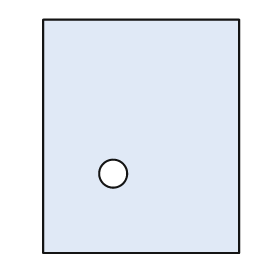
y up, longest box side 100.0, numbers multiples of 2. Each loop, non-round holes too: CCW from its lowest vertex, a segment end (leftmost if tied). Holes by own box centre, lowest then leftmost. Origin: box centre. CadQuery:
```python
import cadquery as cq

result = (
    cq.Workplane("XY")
    .moveTo(-42.0, -50.0)
    .lineTo(42.0, -50.0)
    .lineTo(42.0, 50.0)
    .lineTo(-42.0, 50.0)
    .close()
    .moveTo(-12.0, -16.0)
    .circle(6.0)
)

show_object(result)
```